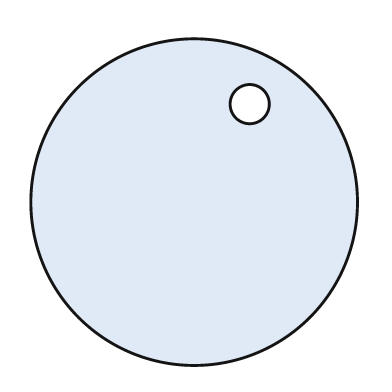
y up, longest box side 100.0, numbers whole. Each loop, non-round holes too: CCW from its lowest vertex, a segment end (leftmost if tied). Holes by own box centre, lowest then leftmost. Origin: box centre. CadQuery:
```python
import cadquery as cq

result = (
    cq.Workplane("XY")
    .moveTo(0.0, 0.0)
    .circle(50.0)
    .moveTo(17.0, 30.0)
    .circle(6.0)
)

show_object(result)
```